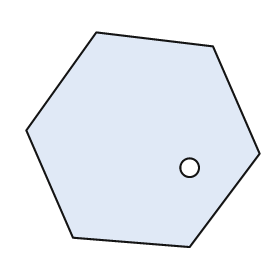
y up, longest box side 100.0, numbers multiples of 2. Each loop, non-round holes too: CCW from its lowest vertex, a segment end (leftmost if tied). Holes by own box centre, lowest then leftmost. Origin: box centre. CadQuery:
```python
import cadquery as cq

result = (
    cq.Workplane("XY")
    .moveTo(20.0, -46.0)
    .lineTo(50.0, -6.0)
    .lineTo(30.0, 40.0)
    .lineTo(-20.0, 46.0)
    .lineTo(-50.0, 4.0)
    .lineTo(-30.0, -42.0)
    .close()
    .moveTo(20.0, -12.0)
    .circle(4.0)
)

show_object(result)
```